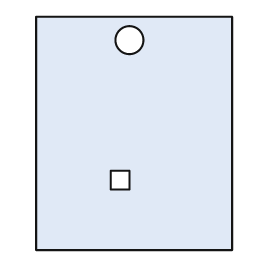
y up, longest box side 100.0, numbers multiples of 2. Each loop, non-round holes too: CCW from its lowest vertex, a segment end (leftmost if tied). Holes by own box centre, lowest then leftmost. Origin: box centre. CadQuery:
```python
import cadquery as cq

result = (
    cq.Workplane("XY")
    .moveTo(-42.0, -50.0)
    .lineTo(42.0, -50.0)
    .lineTo(42.0, 50.0)
    .lineTo(-42.0, 50.0)
    .close()
    .moveTo(-10.0, -24.0)
    .lineTo(-2.0, -24.0)
    .lineTo(-2.0, -16.0)
    .lineTo(-10.0, -16.0)
    .close()
    .moveTo(-2.0, 40.0)
    .circle(6.0)
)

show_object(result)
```